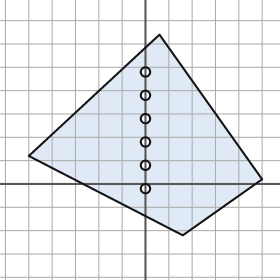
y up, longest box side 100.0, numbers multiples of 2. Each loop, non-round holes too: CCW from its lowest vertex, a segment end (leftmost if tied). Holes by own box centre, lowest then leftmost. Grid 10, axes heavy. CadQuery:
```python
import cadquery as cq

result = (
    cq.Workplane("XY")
    .moveTo(16.0, -22.0)
    .lineTo(50.0, 2.0)
    .lineTo(6.0, 64.0)
    .lineTo(-50.0, 12.0)
    .close()
    .moveTo(0.0, -2.0)
    .circle(2.0)
    .moveTo(0.0, 8.0)
    .circle(2.0)
    .moveTo(0.0, 18.0)
    .circle(2.0)
    .moveTo(0.0, 28.0)
    .circle(2.0)
    .moveTo(0.0, 38.0)
    .circle(2.0)
    .moveTo(0.0, 48.0)
    .circle(2.0)
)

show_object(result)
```